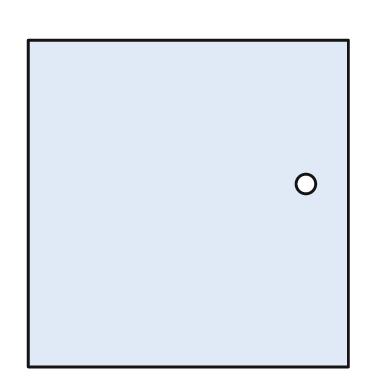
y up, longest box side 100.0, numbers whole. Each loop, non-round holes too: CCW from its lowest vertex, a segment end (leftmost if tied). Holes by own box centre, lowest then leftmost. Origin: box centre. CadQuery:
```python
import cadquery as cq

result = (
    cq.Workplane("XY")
    .moveTo(-49.0, -50.0)
    .lineTo(49.0, -50.0)
    .lineTo(49.0, 50.0)
    .lineTo(-49.0, 50.0)
    .close()
    .moveTo(36.0, 6.0)
    .circle(3.0)
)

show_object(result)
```